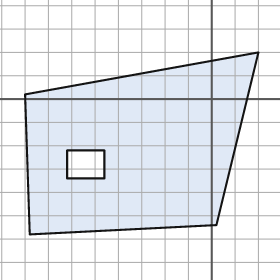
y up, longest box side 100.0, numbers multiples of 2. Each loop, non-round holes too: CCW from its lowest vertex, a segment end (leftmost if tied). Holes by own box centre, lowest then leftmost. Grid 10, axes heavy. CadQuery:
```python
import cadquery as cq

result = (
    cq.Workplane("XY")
    .moveTo(-78.0, -58.0)
    .lineTo(2.0, -54.0)
    .lineTo(20.0, 20.0)
    .lineTo(-80.0, 2.0)
    .close()
    .moveTo(-62.0, -34.0)
    .lineTo(-46.0, -34.0)
    .lineTo(-46.0, -22.0)
    .lineTo(-62.0, -22.0)
    .close()
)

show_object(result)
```